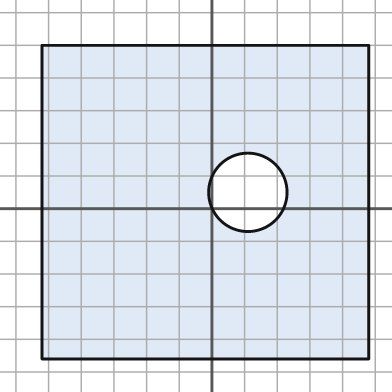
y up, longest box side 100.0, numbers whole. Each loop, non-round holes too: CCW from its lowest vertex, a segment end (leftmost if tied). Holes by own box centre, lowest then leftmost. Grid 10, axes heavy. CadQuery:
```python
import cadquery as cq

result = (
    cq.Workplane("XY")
    .moveTo(-52.0, -46.0)
    .lineTo(48.0, -46.0)
    .lineTo(48.0, 50.0)
    .lineTo(-52.0, 50.0)
    .close()
    .moveTo(11.0, 5.0)
    .circle(12.0)
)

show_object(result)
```